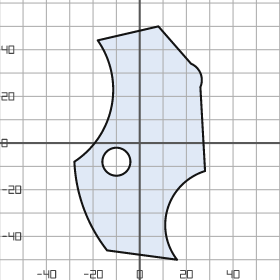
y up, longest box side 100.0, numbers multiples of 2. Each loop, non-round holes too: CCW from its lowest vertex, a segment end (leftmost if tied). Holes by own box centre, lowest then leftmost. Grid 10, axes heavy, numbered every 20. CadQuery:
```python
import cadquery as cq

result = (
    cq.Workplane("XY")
    .moveTo(16.0, -50.0)
    .threePointArc((12.0, -28.0), (28.0, -12.0))
    .lineTo(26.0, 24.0)
    .threePointArc((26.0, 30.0), (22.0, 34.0))
    .lineTo(8.0, 50.0)
    .lineTo(-18.0, 44.0)
    .threePointArc((-12.0, 16.0), (-28.0, -8.0))
    .threePointArc((-24.0, -28.0), (-14.0, -46.0))
    .close()
    .moveTo(-10.0, -8.0)
    .circle(6.0)
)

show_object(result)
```